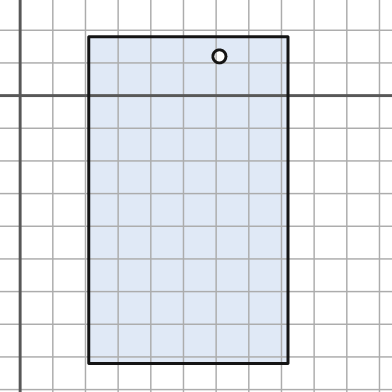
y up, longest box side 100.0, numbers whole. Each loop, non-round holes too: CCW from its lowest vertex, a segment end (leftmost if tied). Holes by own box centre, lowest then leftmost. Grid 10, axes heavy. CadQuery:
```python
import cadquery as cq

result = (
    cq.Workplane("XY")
    .moveTo(21.0, -82.0)
    .lineTo(82.0, -82.0)
    .lineTo(82.0, 18.0)
    .lineTo(21.0, 18.0)
    .close()
    .moveTo(61.0, 12.0)
    .circle(2.0)
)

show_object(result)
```